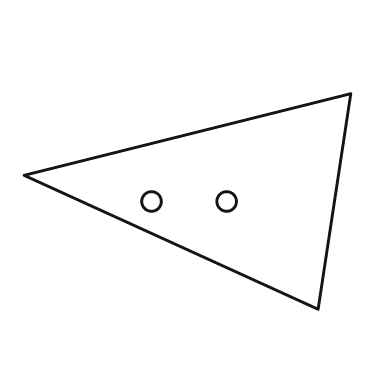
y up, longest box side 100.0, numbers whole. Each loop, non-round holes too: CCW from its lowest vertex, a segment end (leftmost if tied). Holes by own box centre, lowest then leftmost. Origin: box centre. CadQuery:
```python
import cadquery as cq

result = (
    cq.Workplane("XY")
    .moveTo(40.0, -33.0)
    .lineTo(50.0, 33.0)
    .lineTo(-50.0, 8.0)
    .close()
    .moveTo(-11.0, 0.0)
    .circle(3.0)
    .moveTo(12.0, 0.0)
    .circle(3.0)
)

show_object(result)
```